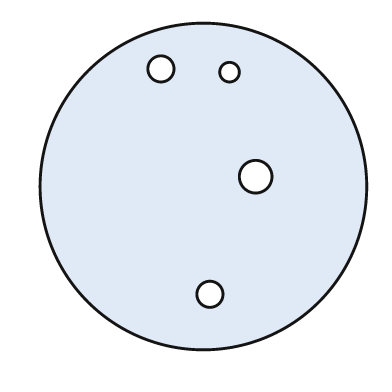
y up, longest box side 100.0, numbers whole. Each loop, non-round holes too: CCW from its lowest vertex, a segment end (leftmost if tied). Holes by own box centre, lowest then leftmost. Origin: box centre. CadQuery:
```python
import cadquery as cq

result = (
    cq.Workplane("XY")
    .moveTo(0.0, 0.0)
    .circle(50.0)
    .moveTo(2.0, -33.0)
    .circle(4.0)
    .moveTo(16.0, 3.0)
    .circle(5.0)
    .moveTo(8.0, 35.0)
    .circle(3.0)
    .moveTo(-13.0, 36.0)
    .circle(4.0)
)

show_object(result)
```